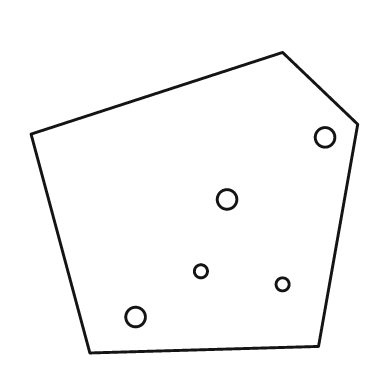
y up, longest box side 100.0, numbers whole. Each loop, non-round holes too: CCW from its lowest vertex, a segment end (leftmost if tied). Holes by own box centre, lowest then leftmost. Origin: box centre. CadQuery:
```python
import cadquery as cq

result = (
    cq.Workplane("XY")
    .moveTo(-32.0, -46.0)
    .lineTo(38.0, -44.0)
    .lineTo(50.0, 24.0)
    .lineTo(27.0, 46.0)
    .lineTo(-50.0, 21.0)
    .close()
    .moveTo(-18.0, -35.0)
    .circle(3.0)
    .moveTo(27.0, -25.0)
    .circle(2.0)
    .moveTo(2.0, -21.0)
    .circle(2.0)
    .moveTo(10.0, 1.0)
    .circle(3.0)
    .moveTo(40.0, 20.0)
    .circle(3.0)
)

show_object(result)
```